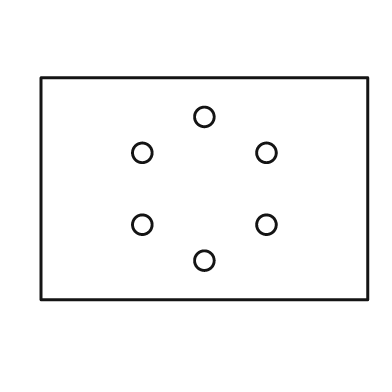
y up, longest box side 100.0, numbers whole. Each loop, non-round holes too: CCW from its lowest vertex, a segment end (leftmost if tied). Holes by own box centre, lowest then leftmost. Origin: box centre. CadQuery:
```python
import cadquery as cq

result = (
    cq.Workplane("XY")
    .moveTo(-50.0, -34.0)
    .lineTo(50.0, -34.0)
    .lineTo(50.0, 34.0)
    .lineTo(-50.0, 34.0)
    .close()
    .moveTo(0.0, -22.0)
    .circle(3.0)
    .moveTo(-19.0, -11.0)
    .circle(3.0)
    .moveTo(19.0, -11.0)
    .circle(3.0)
    .moveTo(-19.0, 11.0)
    .circle(3.0)
    .moveTo(19.0, 11.0)
    .circle(3.0)
    .moveTo(0.0, 22.0)
    .circle(3.0)
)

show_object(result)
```